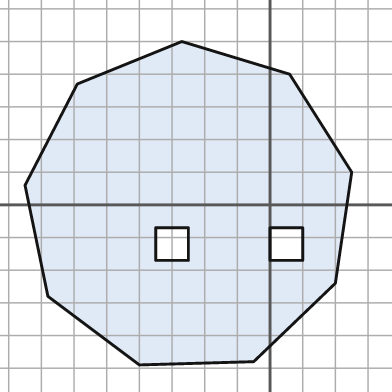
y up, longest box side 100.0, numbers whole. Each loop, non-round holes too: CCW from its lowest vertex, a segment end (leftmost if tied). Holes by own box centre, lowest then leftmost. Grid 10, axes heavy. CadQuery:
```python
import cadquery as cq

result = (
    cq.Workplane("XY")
    .moveTo(-40.0, -49.0)
    .lineTo(-5.0, -48.0)
    .lineTo(20.0, -24.0)
    .lineTo(25.0, 10.0)
    .lineTo(6.0, 40.0)
    .lineTo(-27.0, 50.0)
    .lineTo(-59.0, 37.0)
    .lineTo(-75.0, 6.0)
    .lineTo(-68.0, -28.0)
    .close()
    .moveTo(-35.0, -17.0)
    .lineTo(-25.0, -17.0)
    .lineTo(-25.0, -7.0)
    .lineTo(-35.0, -7.0)
    .close()
    .moveTo(0.0, -17.0)
    .lineTo(10.0, -17.0)
    .lineTo(10.0, -7.0)
    .lineTo(0.0, -7.0)
    .close()
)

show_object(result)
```